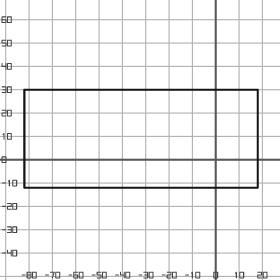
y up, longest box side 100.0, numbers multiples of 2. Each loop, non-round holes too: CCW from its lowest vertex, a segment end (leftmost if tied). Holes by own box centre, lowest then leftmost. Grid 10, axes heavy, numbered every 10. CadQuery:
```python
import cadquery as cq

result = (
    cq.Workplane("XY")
    .moveTo(-82.0, -12.0)
    .lineTo(18.0, -12.0)
    .lineTo(18.0, 30.0)
    .lineTo(-82.0, 30.0)
    .close()
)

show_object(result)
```